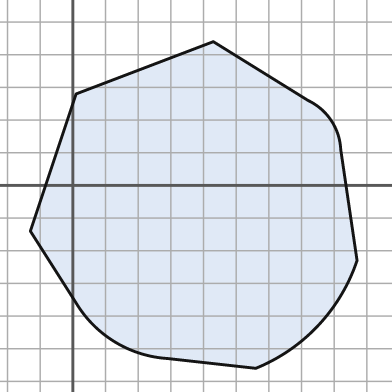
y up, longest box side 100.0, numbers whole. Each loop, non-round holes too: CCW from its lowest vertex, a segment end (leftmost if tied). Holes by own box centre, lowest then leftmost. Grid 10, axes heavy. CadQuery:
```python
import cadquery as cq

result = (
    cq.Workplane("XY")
    .moveTo(56.0, -56.0)
    .threePointArc((75.0, -43.0), (87.0, -23.0))
    .lineTo(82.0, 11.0)
    .threePointArc((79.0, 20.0), (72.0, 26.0))
    .lineTo(43.0, 44.0)
    .lineTo(1.0, 28.0)
    .lineTo(-13.0, -14.0)
    .lineTo(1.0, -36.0)
    .threePointArc((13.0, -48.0), (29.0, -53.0))
    .close()
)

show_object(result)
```